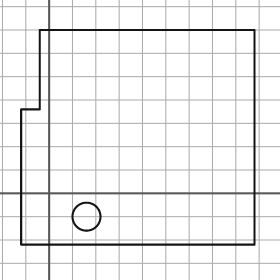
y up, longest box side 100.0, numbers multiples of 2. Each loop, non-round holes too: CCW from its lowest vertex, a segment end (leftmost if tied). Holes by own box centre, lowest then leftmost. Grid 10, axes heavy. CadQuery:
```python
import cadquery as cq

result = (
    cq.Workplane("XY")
    .moveTo(-12.0, -22.0)
    .lineTo(88.0, -22.0)
    .lineTo(88.0, 70.0)
    .lineTo(-4.0, 70.0)
    .lineTo(-4.0, 36.0)
    .lineTo(-12.0, 36.0)
    .close()
    .moveTo(16.0, -10.0)
    .circle(6.0)
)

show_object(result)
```